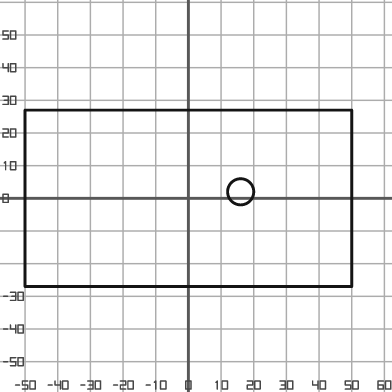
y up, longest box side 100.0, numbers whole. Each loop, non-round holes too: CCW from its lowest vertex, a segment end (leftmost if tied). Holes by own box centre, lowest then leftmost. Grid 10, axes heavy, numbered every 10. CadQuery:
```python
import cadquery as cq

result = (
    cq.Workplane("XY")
    .moveTo(-50.0, -27.0)
    .lineTo(50.0, -27.0)
    .lineTo(50.0, 27.0)
    .lineTo(-50.0, 27.0)
    .close()
    .moveTo(16.0, 2.0)
    .circle(4.0)
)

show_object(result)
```